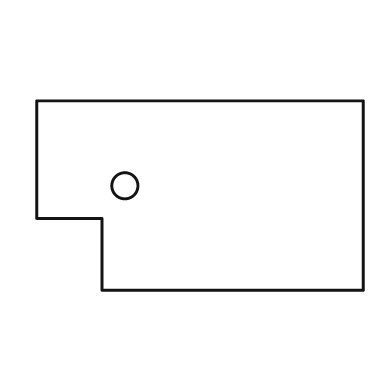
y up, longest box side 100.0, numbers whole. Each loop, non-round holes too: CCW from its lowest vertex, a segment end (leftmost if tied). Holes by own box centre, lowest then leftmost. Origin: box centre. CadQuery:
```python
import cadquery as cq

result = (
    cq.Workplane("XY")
    .moveTo(-30.0, -29.0)
    .lineTo(50.0, -29.0)
    .lineTo(50.0, 29.0)
    .lineTo(-50.0, 29.0)
    .lineTo(-50.0, -7.0)
    .lineTo(-30.0, -7.0)
    .close()
    .moveTo(-23.0, 3.0)
    .circle(4.0)
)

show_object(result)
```